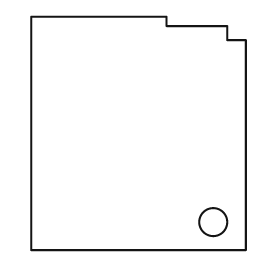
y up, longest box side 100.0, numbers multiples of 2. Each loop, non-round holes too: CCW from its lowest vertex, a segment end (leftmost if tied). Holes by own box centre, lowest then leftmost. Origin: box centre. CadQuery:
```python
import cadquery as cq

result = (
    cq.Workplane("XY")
    .moveTo(-46.0, -50.0)
    .lineTo(46.0, -50.0)
    .lineTo(46.0, 40.0)
    .lineTo(38.0, 40.0)
    .lineTo(38.0, 46.0)
    .lineTo(12.0, 46.0)
    .lineTo(12.0, 50.0)
    .lineTo(-46.0, 50.0)
    .close()
    .moveTo(32.0, -38.0)
    .circle(6.0)
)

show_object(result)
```